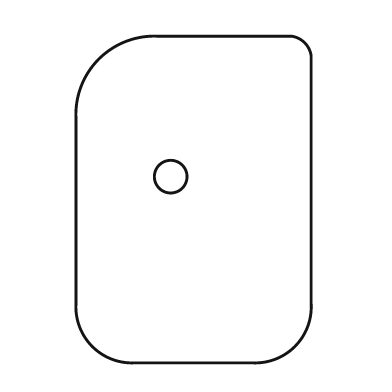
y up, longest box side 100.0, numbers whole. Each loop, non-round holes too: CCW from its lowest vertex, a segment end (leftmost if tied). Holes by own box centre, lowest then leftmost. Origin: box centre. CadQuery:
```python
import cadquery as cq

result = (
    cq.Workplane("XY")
    .moveTo(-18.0, -50.0)
    .lineTo(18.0, -50.0)
    .threePointArc((31.0, -45.0), (36.0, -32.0))
    .lineTo(36.0, 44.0)
    .threePointArc((34.0, 48.0), (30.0, 50.0))
    .lineTo(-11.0, 50.0)
    .threePointArc((-29.0, 43.0), (-36.0, 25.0))
    .lineTo(-36.0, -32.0)
    .threePointArc((-31.0, -45.0), (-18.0, -50.0))
    .close()
    .moveTo(-7.0, 7.0)
    .circle(5.0)
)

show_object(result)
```